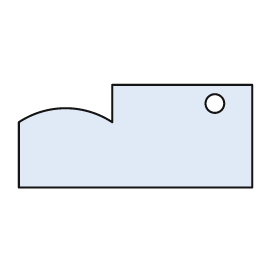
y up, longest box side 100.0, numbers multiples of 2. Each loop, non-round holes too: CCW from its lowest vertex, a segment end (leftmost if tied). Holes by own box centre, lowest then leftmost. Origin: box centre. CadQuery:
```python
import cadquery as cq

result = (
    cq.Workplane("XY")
    .moveTo(-50.0, -22.0)
    .lineTo(50.0, -22.0)
    .lineTo(50.0, 22.0)
    .lineTo(-10.0, 22.0)
    .lineTo(-10.0, 6.0)
    .threePointArc((-30.0, 12.0), (-50.0, 6.0))
    .close()
    .moveTo(34.0, 14.0)
    .circle(4.0)
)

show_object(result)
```